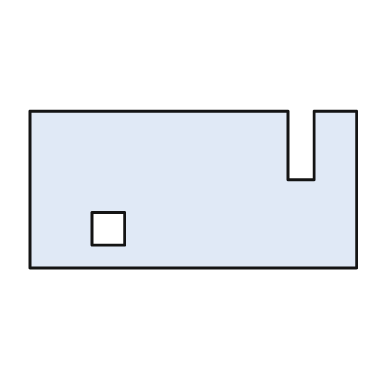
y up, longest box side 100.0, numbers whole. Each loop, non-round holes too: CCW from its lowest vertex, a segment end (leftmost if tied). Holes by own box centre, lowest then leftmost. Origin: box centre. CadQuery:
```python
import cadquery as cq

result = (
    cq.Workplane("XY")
    .moveTo(-50.0, -24.0)
    .lineTo(50.0, -24.0)
    .lineTo(50.0, 24.0)
    .lineTo(37.0, 24.0)
    .lineTo(37.0, 3.0)
    .lineTo(29.0, 3.0)
    .lineTo(29.0, 24.0)
    .lineTo(-50.0, 24.0)
    .close()
    .moveTo(-31.0, -17.0)
    .lineTo(-21.0, -17.0)
    .lineTo(-21.0, -7.0)
    .lineTo(-31.0, -7.0)
    .close()
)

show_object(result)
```